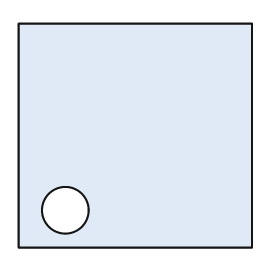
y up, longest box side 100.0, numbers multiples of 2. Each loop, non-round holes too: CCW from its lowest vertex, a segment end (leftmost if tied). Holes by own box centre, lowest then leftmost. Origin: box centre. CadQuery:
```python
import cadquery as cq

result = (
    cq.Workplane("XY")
    .moveTo(-50.0, -48.0)
    .lineTo(50.0, -48.0)
    .lineTo(50.0, 48.0)
    .lineTo(-50.0, 48.0)
    .close()
    .moveTo(-30.0, -32.0)
    .circle(10.0)
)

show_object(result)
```